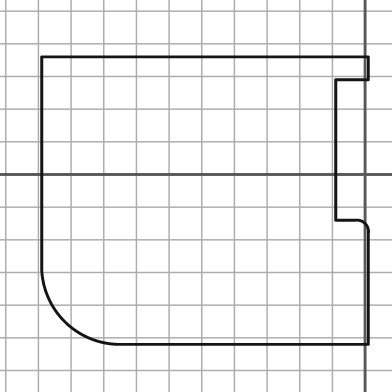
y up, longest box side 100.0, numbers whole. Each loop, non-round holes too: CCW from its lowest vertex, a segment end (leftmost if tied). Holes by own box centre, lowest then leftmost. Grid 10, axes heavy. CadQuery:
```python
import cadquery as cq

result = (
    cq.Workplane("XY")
    .moveTo(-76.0, -52.0)
    .lineTo(1.0, -52.0)
    .lineTo(1.0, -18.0)
    .threePointArc((0.0, -15.0), (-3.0, -14.0))
    .lineTo(-9.0, -14.0)
    .lineTo(-9.0, 29.0)
    .lineTo(1.0, 29.0)
    .lineTo(1.0, 36.0)
    .lineTo(-99.0, 36.0)
    .lineTo(-99.0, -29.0)
    .threePointArc((-92.0, -45.0), (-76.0, -52.0))
    .close()
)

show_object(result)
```